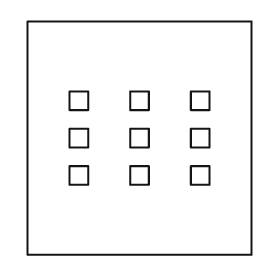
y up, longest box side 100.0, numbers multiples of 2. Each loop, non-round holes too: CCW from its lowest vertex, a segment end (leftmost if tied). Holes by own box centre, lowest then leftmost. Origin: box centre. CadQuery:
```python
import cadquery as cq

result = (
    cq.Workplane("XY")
    .moveTo(-48.0, -50.0)
    .lineTo(48.0, -50.0)
    .lineTo(48.0, 50.0)
    .lineTo(-48.0, 50.0)
    .close()
    .moveTo(-30.0, -20.0)
    .lineTo(-22.0, -20.0)
    .lineTo(-22.0, -12.0)
    .lineTo(-30.0, -12.0)
    .close()
    .moveTo(-4.0, -20.0)
    .lineTo(4.0, -20.0)
    .lineTo(4.0, -12.0)
    .lineTo(-4.0, -12.0)
    .close()
    .moveTo(22.0, -20.0)
    .lineTo(30.0, -20.0)
    .lineTo(30.0, -12.0)
    .lineTo(22.0, -12.0)
    .close()
    .moveTo(-30.0, -4.0)
    .lineTo(-22.0, -4.0)
    .lineTo(-22.0, 4.0)
    .lineTo(-30.0, 4.0)
    .close()
    .moveTo(-4.0, -4.0)
    .lineTo(4.0, -4.0)
    .lineTo(4.0, 4.0)
    .lineTo(-4.0, 4.0)
    .close()
    .moveTo(22.0, -4.0)
    .lineTo(30.0, -4.0)
    .lineTo(30.0, 4.0)
    .lineTo(22.0, 4.0)
    .close()
    .moveTo(-30.0, 12.0)
    .lineTo(-22.0, 12.0)
    .lineTo(-22.0, 20.0)
    .lineTo(-30.0, 20.0)
    .close()
    .moveTo(-4.0, 12.0)
    .lineTo(4.0, 12.0)
    .lineTo(4.0, 20.0)
    .lineTo(-4.0, 20.0)
    .close()
    .moveTo(22.0, 12.0)
    .lineTo(30.0, 12.0)
    .lineTo(30.0, 20.0)
    .lineTo(22.0, 20.0)
    .close()
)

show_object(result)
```